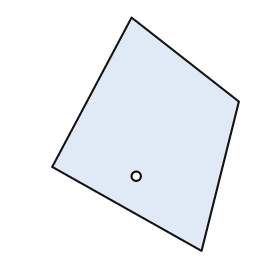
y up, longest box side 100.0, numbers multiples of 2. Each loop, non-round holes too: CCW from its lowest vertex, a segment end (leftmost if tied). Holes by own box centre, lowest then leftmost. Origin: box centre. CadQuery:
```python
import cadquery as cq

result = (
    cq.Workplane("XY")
    .moveTo(24.0, -50.0)
    .lineTo(40.0, 14.0)
    .lineTo(-6.0, 50.0)
    .lineTo(-40.0, -14.0)
    .close()
    .moveTo(-4.0, -18.0)
    .circle(2.0)
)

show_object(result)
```